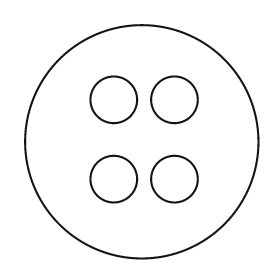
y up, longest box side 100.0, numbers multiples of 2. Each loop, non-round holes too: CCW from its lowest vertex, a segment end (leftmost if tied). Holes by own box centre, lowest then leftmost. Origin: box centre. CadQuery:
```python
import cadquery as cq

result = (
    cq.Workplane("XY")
    .moveTo(0.0, 0.0)
    .circle(50.0)
    .moveTo(-12.0, -16.0)
    .circle(10.0)
    .moveTo(14.0, -16.0)
    .circle(10.0)
    .moveTo(-12.0, 18.0)
    .circle(10.0)
    .moveTo(14.0, 18.0)
    .circle(10.0)
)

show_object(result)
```